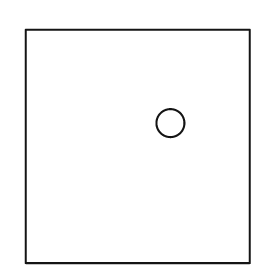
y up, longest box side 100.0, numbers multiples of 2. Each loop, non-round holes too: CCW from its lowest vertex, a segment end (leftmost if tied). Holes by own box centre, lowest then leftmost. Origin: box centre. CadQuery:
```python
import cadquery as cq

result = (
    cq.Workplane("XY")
    .moveTo(-48.0, -50.0)
    .lineTo(48.0, -50.0)
    .lineTo(48.0, 50.0)
    .lineTo(-48.0, 50.0)
    .close()
    .moveTo(14.0, 10.0)
    .circle(6.0)
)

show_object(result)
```